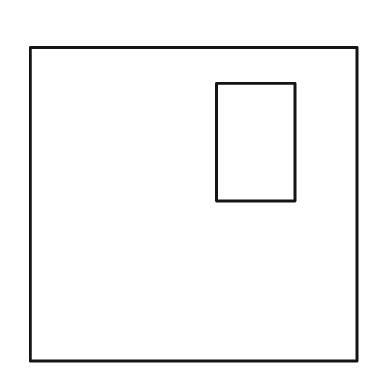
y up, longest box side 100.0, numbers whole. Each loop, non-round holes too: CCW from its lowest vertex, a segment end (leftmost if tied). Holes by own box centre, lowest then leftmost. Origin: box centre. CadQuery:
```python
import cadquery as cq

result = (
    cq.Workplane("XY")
    .moveTo(-50.0, -48.0)
    .lineTo(50.0, -48.0)
    .lineTo(50.0, 48.0)
    .lineTo(-50.0, 48.0)
    .close()
    .moveTo(7.0, 1.0)
    .lineTo(31.0, 1.0)
    .lineTo(31.0, 37.0)
    .lineTo(7.0, 37.0)
    .close()
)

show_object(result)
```